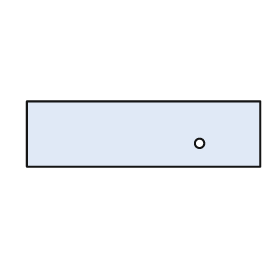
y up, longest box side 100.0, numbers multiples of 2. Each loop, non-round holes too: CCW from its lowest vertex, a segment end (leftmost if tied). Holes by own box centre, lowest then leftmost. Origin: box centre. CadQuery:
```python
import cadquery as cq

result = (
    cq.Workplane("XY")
    .moveTo(-50.0, -14.0)
    .lineTo(50.0, -14.0)
    .lineTo(50.0, 14.0)
    .lineTo(-50.0, 14.0)
    .close()
    .moveTo(24.0, -4.0)
    .circle(2.0)
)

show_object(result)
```